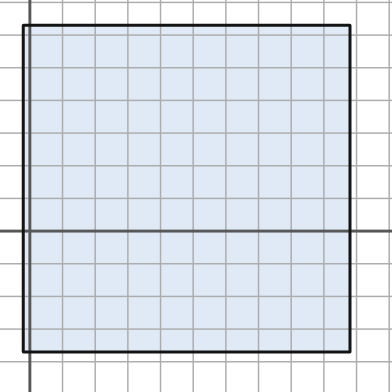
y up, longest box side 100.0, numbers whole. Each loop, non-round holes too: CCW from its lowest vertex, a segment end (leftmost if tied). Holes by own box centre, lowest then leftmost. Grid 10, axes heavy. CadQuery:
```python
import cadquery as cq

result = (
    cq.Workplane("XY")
    .moveTo(-2.0, -37.0)
    .lineTo(98.0, -37.0)
    .lineTo(98.0, 63.0)
    .lineTo(-2.0, 63.0)
    .close()
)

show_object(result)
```